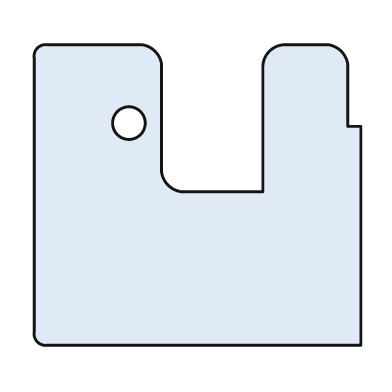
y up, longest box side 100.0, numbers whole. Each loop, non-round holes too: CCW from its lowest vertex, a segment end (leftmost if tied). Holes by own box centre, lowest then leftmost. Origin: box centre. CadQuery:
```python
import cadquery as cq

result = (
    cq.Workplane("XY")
    .moveTo(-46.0, -46.0)
    .lineTo(50.0, -46.0)
    .lineTo(50.0, 21.0)
    .lineTo(46.0, 21.0)
    .lineTo(46.0, 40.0)
    .threePointArc((44.0, 44.0), (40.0, 46.0))
    .lineTo(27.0, 46.0)
    .threePointArc((22.0, 44.0), (20.0, 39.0))
    .lineTo(20.0, 1.0)
    .lineTo(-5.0, 1.0)
    .threePointArc((-9.0, 3.0), (-11.0, 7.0))
    .lineTo(-11.0, 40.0)
    .threePointArc((-13.0, 44.0), (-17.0, 46.0))
    .lineTo(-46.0, 46.0)
    .threePointArc((-49.0, 45.0), (-50.0, 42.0))
    .lineTo(-50.0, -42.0)
    .threePointArc((-49.0, -45.0), (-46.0, -46.0))
    .close()
    .moveTo(-21.0, 22.0)
    .circle(5.0)
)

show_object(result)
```